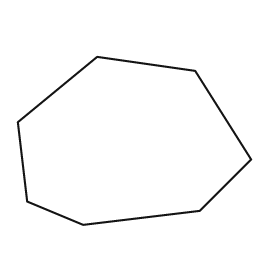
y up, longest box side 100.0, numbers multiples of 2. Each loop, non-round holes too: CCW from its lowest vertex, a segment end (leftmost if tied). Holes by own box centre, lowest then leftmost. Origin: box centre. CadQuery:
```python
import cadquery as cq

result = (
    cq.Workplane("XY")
    .moveTo(-22.0, -36.0)
    .lineTo(28.0, -30.0)
    .lineTo(50.0, -8.0)
    .lineTo(26.0, 30.0)
    .lineTo(-16.0, 36.0)
    .lineTo(-50.0, 8.0)
    .lineTo(-46.0, -26.0)
    .close()
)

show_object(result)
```